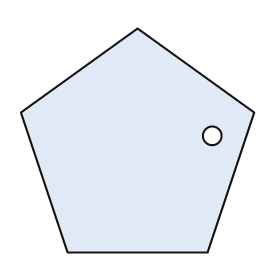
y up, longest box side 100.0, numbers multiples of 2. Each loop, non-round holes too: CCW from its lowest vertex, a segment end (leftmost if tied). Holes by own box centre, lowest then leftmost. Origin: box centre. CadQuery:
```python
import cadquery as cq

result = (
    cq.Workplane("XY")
    .moveTo(-30.0, -48.0)
    .lineTo(30.0, -48.0)
    .lineTo(50.0, 12.0)
    .lineTo(0.0, 48.0)
    .lineTo(-50.0, 12.0)
    .close()
    .moveTo(32.0, 2.0)
    .circle(4.0)
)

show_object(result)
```